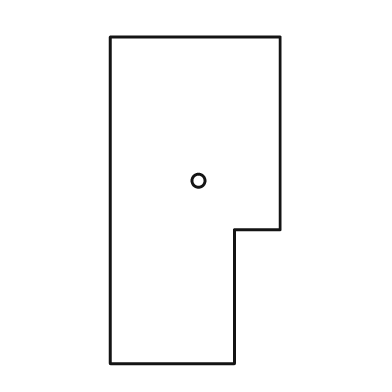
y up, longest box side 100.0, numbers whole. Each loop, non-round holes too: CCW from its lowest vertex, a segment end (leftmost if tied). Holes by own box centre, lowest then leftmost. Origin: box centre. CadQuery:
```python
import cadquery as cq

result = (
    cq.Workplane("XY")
    .moveTo(-26.0, -50.0)
    .lineTo(12.0, -50.0)
    .lineTo(12.0, -9.0)
    .lineTo(26.0, -9.0)
    .lineTo(26.0, 50.0)
    .lineTo(-26.0, 50.0)
    .close()
    .moveTo(1.0, 6.0)
    .circle(2.0)
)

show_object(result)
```